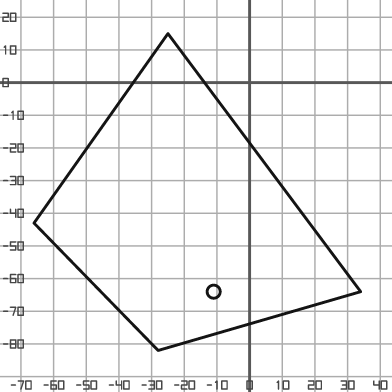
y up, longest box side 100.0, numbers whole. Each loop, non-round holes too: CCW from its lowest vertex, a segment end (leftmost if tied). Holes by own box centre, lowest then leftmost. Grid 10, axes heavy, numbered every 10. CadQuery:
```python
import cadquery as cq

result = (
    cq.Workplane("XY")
    .moveTo(-28.0, -82.0)
    .lineTo(34.0, -64.0)
    .lineTo(-25.0, 15.0)
    .lineTo(-66.0, -43.0)
    .close()
    .moveTo(-11.0, -64.0)
    .circle(2.0)
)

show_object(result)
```